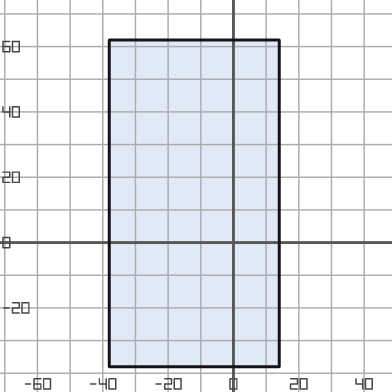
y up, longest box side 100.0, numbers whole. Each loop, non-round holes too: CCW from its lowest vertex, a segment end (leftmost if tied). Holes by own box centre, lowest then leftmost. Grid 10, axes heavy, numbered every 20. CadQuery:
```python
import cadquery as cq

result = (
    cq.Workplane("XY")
    .moveTo(-38.0, -38.0)
    .lineTo(14.0, -38.0)
    .lineTo(14.0, 62.0)
    .lineTo(-38.0, 62.0)
    .close()
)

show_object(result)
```